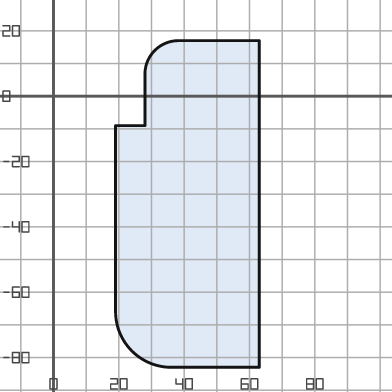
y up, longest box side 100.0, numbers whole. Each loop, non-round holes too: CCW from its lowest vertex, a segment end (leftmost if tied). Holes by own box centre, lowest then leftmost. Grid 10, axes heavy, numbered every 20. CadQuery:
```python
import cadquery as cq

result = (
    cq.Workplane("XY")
    .moveTo(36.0, -83.0)
    .lineTo(63.0, -83.0)
    .lineTo(63.0, 17.0)
    .lineTo(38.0, 17.0)
    .threePointArc((31.0, 14.0), (28.0, 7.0))
    .lineTo(28.0, -9.0)
    .lineTo(19.0, -9.0)
    .lineTo(19.0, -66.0)
    .threePointArc((24.0, -78.0), (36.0, -83.0))
    .close()
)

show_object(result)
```